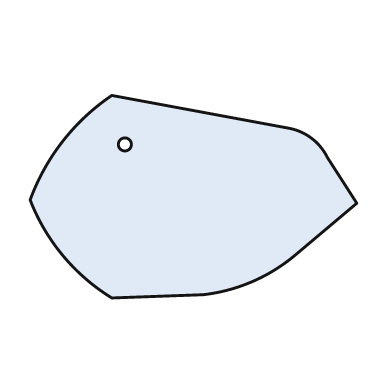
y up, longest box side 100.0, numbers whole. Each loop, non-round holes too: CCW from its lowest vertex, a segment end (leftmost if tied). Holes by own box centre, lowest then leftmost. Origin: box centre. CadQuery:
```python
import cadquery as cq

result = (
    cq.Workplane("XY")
    .moveTo(-25.0, -31.0)
    .lineTo(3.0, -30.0)
    .threePointArc((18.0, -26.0), (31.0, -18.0))
    .lineTo(50.0, -2.0)
    .lineTo(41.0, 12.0)
    .threePointArc((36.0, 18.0), (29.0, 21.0))
    .lineTo(-25.0, 31.0)
    .threePointArc((-40.0, 17.0), (-50.0, -1.0))
    .threePointArc((-40.0, -18.0), (-25.0, -31.0))
    .close()
    .moveTo(-21.0, 16.0)
    .circle(2.0)
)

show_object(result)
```